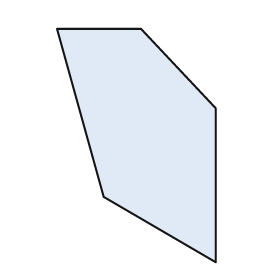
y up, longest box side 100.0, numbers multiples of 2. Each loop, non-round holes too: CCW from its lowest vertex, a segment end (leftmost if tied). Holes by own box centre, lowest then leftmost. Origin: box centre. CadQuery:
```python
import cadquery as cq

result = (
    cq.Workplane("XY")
    .moveTo(34.0, -50.0)
    .lineTo(34.0, 16.0)
    .lineTo(2.0, 50.0)
    .lineTo(-34.0, 50.0)
    .lineTo(-14.0, -22.0)
    .close()
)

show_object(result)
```